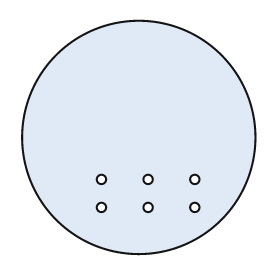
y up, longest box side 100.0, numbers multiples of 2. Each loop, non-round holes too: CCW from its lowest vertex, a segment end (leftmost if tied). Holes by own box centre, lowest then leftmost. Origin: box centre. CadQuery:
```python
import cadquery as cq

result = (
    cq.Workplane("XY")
    .moveTo(0.0, 0.0)
    .circle(50.0)
    .moveTo(-16.0, -30.0)
    .circle(2.0)
    .moveTo(4.0, -30.0)
    .circle(2.0)
    .moveTo(24.0, -30.0)
    .circle(2.0)
    .moveTo(-16.0, -18.0)
    .circle(2.0)
    .moveTo(4.0, -18.0)
    .circle(2.0)
    .moveTo(24.0, -18.0)
    .circle(2.0)
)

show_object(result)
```